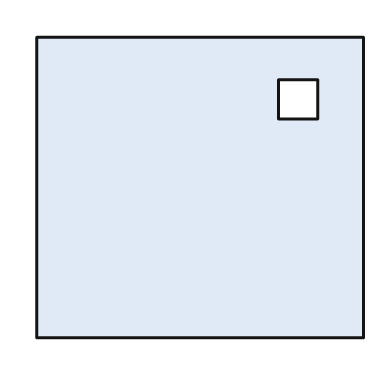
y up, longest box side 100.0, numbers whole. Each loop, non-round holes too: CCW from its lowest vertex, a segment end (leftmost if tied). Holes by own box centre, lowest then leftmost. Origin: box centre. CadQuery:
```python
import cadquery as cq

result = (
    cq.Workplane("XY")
    .moveTo(-50.0, -46.0)
    .lineTo(50.0, -46.0)
    .lineTo(50.0, 46.0)
    .lineTo(-50.0, 46.0)
    .close()
    .moveTo(24.0, 21.0)
    .lineTo(36.0, 21.0)
    .lineTo(36.0, 33.0)
    .lineTo(24.0, 33.0)
    .close()
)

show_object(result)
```